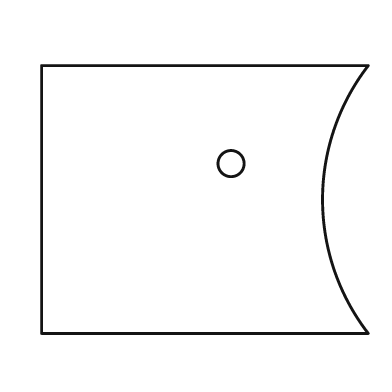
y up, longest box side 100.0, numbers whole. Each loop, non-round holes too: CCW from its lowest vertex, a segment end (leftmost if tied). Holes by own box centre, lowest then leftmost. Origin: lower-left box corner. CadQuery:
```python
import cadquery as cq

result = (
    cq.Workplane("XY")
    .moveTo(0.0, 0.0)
    .lineTo(100.0, 0.0)
    .threePointArc((86.0, 41.0), (100.0, 82.0))
    .lineTo(0.0, 82.0)
    .close()
    .moveTo(58.0, 52.0)
    .circle(4.0)
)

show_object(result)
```